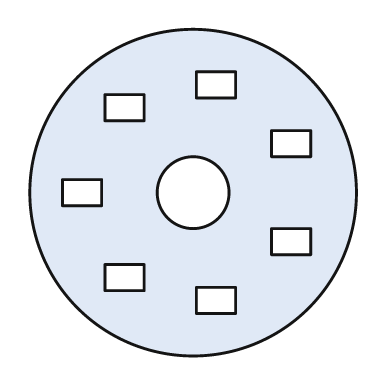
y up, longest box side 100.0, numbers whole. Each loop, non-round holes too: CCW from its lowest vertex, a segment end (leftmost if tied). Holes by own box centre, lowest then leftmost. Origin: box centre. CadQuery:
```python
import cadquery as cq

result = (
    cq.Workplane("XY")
    .moveTo(0.0, 0.0)
    .circle(50.0)
    .moveTo(1.0, -37.0)
    .lineTo(13.0, -37.0)
    .lineTo(13.0, -29.0)
    .lineTo(1.0, -29.0)
    .close()
    .moveTo(-27.0, -30.0)
    .lineTo(-15.0, -30.0)
    .lineTo(-15.0, -22.0)
    .lineTo(-27.0, -22.0)
    .close()
    .moveTo(24.0, -19.0)
    .lineTo(36.0, -19.0)
    .lineTo(36.0, -11.0)
    .lineTo(24.0, -11.0)
    .close()
    .moveTo(-40.0, -4.0)
    .lineTo(-28.0, -4.0)
    .lineTo(-28.0, 4.0)
    .lineTo(-40.0, 4.0)
    .close()
    .moveTo(0.0, 0.0)
    .circle(11.0)
    .moveTo(24.0, 11.0)
    .lineTo(36.0, 11.0)
    .lineTo(36.0, 19.0)
    .lineTo(24.0, 19.0)
    .close()
    .moveTo(-27.0, 22.0)
    .lineTo(-15.0, 22.0)
    .lineTo(-15.0, 30.0)
    .lineTo(-27.0, 30.0)
    .close()
    .moveTo(1.0, 29.0)
    .lineTo(13.0, 29.0)
    .lineTo(13.0, 37.0)
    .lineTo(1.0, 37.0)
    .close()
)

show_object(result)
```